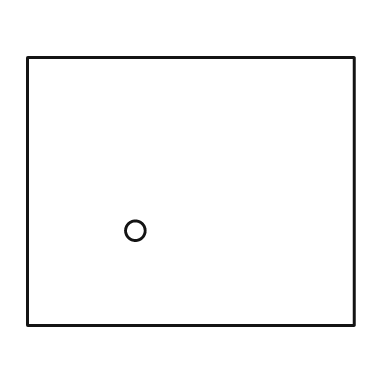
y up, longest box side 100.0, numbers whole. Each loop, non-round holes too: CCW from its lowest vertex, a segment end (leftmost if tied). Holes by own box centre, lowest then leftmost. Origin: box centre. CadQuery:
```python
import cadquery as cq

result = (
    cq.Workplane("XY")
    .moveTo(-50.0, -41.0)
    .lineTo(50.0, -41.0)
    .lineTo(50.0, 41.0)
    .lineTo(-50.0, 41.0)
    .close()
    .moveTo(-17.0, -12.0)
    .circle(3.0)
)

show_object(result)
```